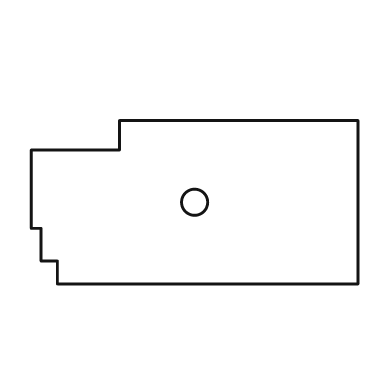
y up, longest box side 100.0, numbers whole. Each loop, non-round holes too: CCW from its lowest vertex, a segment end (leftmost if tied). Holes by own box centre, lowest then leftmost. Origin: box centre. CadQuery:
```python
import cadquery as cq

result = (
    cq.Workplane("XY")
    .moveTo(-42.0, -25.0)
    .lineTo(50.0, -25.0)
    .lineTo(50.0, 25.0)
    .lineTo(-23.0, 25.0)
    .lineTo(-23.0, 16.0)
    .lineTo(-50.0, 16.0)
    .lineTo(-50.0, -8.0)
    .lineTo(-47.0, -8.0)
    .lineTo(-47.0, -18.0)
    .lineTo(-42.0, -18.0)
    .close()
    .moveTo(0.0, 0.0)
    .circle(4.0)
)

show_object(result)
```